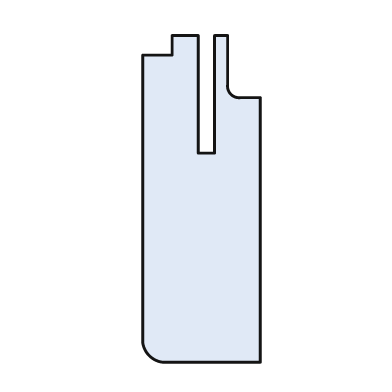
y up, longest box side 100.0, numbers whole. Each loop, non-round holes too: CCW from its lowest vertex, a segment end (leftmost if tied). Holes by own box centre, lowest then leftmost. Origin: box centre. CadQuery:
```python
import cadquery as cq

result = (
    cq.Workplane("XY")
    .moveTo(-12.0, -50.0)
    .lineTo(18.0, -50.0)
    .lineTo(18.0, 31.0)
    .lineTo(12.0, 31.0)
    .threePointArc((9.0, 32.0), (8.0, 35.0))
    .lineTo(8.0, 50.0)
    .lineTo(4.0, 50.0)
    .lineTo(4.0, 14.0)
    .lineTo(-1.0, 14.0)
    .lineTo(-1.0, 50.0)
    .lineTo(-9.0, 50.0)
    .lineTo(-9.0, 44.0)
    .lineTo(-18.0, 44.0)
    .lineTo(-18.0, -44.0)
    .threePointArc((-16.0, -48.0), (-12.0, -50.0))
    .close()
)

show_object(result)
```